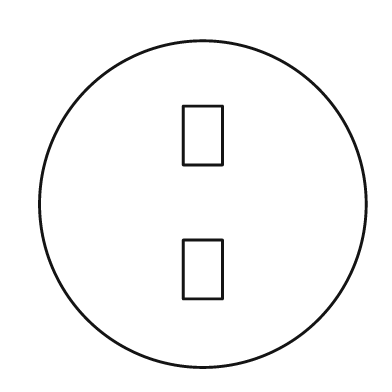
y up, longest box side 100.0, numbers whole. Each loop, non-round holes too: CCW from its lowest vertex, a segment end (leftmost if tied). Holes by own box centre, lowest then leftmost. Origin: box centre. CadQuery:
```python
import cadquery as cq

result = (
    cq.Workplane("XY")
    .moveTo(0.0, 0.0)
    .circle(50.0)
    .moveTo(-6.0, -29.0)
    .lineTo(6.0, -29.0)
    .lineTo(6.0, -11.0)
    .lineTo(-6.0, -11.0)
    .close()
    .moveTo(-6.0, 12.0)
    .lineTo(6.0, 12.0)
    .lineTo(6.0, 30.0)
    .lineTo(-6.0, 30.0)
    .close()
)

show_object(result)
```